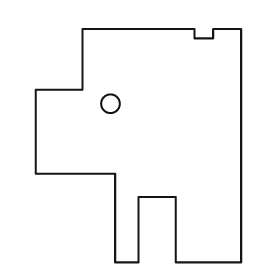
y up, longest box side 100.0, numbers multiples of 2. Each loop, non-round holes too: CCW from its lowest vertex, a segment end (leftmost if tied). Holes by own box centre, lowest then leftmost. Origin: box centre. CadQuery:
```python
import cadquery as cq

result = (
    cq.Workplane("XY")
    .moveTo(-10.0, -50.0)
    .lineTo(0.0, -50.0)
    .lineTo(0.0, -22.0)
    .lineTo(16.0, -22.0)
    .lineTo(16.0, -50.0)
    .lineTo(44.0, -50.0)
    .lineTo(44.0, 50.0)
    .lineTo(32.0, 50.0)
    .lineTo(32.0, 46.0)
    .lineTo(24.0, 46.0)
    .lineTo(24.0, 50.0)
    .lineTo(-24.0, 50.0)
    .lineTo(-24.0, 24.0)
    .lineTo(-44.0, 24.0)
    .lineTo(-44.0, -12.0)
    .lineTo(-10.0, -12.0)
    .close()
    .moveTo(-12.0, 18.0)
    .circle(4.0)
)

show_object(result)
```